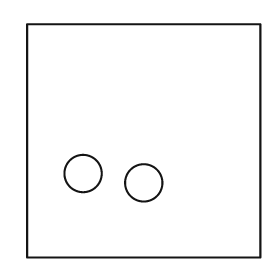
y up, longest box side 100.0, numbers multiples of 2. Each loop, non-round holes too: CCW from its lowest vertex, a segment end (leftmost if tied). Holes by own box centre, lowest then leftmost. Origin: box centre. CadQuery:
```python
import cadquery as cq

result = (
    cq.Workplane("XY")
    .moveTo(-50.0, -50.0)
    .lineTo(50.0, -50.0)
    .lineTo(50.0, 50.0)
    .lineTo(-50.0, 50.0)
    .close()
    .moveTo(0.0, -18.0)
    .circle(8.0)
    .moveTo(-26.0, -14.0)
    .circle(8.0)
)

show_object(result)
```